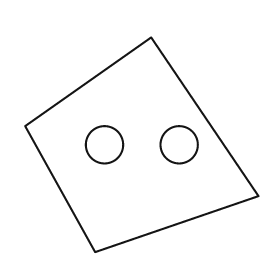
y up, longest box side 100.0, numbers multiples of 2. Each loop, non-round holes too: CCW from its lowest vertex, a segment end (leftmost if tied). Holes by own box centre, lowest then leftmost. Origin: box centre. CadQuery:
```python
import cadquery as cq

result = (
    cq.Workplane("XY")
    .moveTo(-20.0, -46.0)
    .lineTo(50.0, -22.0)
    .lineTo(4.0, 46.0)
    .lineTo(-50.0, 8.0)
    .close()
    .moveTo(-16.0, 0.0)
    .circle(8.0)
    .moveTo(16.0, 0.0)
    .circle(8.0)
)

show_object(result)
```